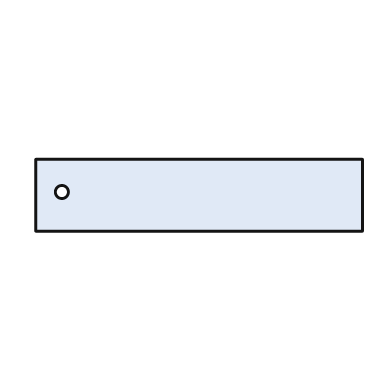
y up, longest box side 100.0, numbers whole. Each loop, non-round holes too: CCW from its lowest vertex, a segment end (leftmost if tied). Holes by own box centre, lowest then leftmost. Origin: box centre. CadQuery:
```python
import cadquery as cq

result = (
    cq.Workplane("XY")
    .moveTo(-50.0, -11.0)
    .lineTo(50.0, -11.0)
    .lineTo(50.0, 11.0)
    .lineTo(-50.0, 11.0)
    .close()
    .moveTo(-42.0, 1.0)
    .circle(2.0)
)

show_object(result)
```